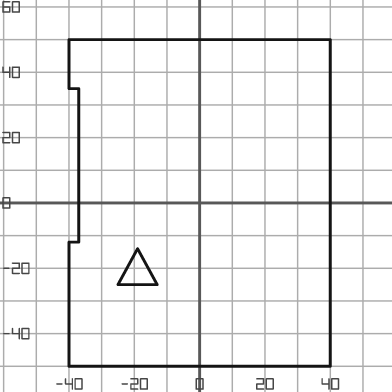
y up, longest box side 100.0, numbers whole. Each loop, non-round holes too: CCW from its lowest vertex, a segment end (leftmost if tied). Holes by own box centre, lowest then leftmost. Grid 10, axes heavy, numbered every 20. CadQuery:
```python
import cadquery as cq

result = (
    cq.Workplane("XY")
    .moveTo(-40.0, -50.0)
    .lineTo(40.0, -50.0)
    .lineTo(40.0, 50.0)
    .lineTo(-40.0, 50.0)
    .lineTo(-40.0, 35.0)
    .lineTo(-37.0, 35.0)
    .lineTo(-37.0, -12.0)
    .lineTo(-40.0, -12.0)
    .close()
    .moveTo(-25.0, -25.0)
    .lineTo(-13.0, -25.0)
    .lineTo(-19.0, -14.0)
    .close()
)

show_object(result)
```